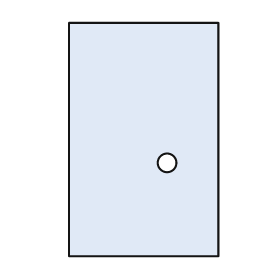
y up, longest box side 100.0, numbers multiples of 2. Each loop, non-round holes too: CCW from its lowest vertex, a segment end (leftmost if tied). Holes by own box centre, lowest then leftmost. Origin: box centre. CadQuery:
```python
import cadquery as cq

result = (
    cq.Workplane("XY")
    .moveTo(-32.0, -50.0)
    .lineTo(32.0, -50.0)
    .lineTo(32.0, 50.0)
    .lineTo(-32.0, 50.0)
    .close()
    .moveTo(10.0, -10.0)
    .circle(4.0)
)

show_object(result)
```